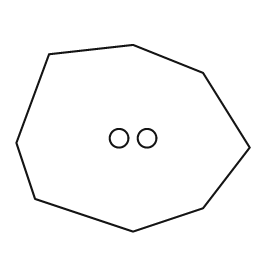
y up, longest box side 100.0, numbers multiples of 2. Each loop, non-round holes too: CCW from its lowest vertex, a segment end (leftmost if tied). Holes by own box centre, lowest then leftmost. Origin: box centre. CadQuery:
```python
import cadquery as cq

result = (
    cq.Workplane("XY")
    .moveTo(0.0, -40.0)
    .lineTo(30.0, -30.0)
    .lineTo(50.0, -4.0)
    .lineTo(30.0, 28.0)
    .lineTo(0.0, 40.0)
    .lineTo(-36.0, 36.0)
    .lineTo(-50.0, -2.0)
    .lineTo(-42.0, -26.0)
    .close()
    .moveTo(-6.0, 0.0)
    .circle(4.0)
    .moveTo(6.0, 0.0)
    .circle(4.0)
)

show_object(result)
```